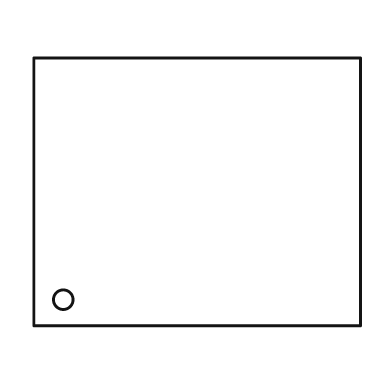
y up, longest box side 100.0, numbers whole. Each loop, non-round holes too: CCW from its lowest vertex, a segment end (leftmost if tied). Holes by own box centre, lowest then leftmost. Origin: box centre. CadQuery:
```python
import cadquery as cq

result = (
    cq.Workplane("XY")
    .moveTo(-50.0, -41.0)
    .lineTo(50.0, -41.0)
    .lineTo(50.0, 41.0)
    .lineTo(-50.0, 41.0)
    .close()
    .moveTo(-41.0, -33.0)
    .circle(3.0)
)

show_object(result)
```